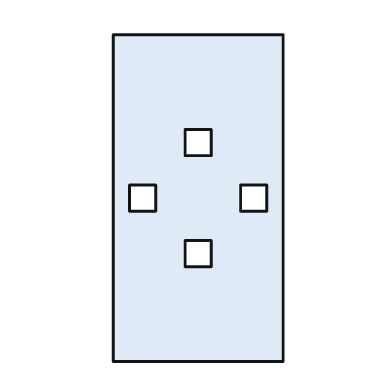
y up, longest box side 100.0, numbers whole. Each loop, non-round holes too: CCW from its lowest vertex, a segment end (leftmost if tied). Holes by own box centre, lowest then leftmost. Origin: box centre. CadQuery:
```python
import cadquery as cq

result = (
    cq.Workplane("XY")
    .moveTo(-26.0, -50.0)
    .lineTo(26.0, -50.0)
    .lineTo(26.0, 50.0)
    .lineTo(-26.0, 50.0)
    .close()
    .moveTo(-4.0, -21.0)
    .lineTo(4.0, -21.0)
    .lineTo(4.0, -13.0)
    .lineTo(-4.0, -13.0)
    .close()
    .moveTo(-21.0, -4.0)
    .lineTo(-13.0, -4.0)
    .lineTo(-13.0, 4.0)
    .lineTo(-21.0, 4.0)
    .close()
    .moveTo(13.0, -4.0)
    .lineTo(21.0, -4.0)
    .lineTo(21.0, 4.0)
    .lineTo(13.0, 4.0)
    .close()
    .moveTo(-4.0, 13.0)
    .lineTo(4.0, 13.0)
    .lineTo(4.0, 21.0)
    .lineTo(-4.0, 21.0)
    .close()
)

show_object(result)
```